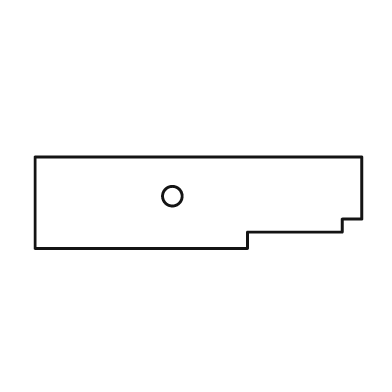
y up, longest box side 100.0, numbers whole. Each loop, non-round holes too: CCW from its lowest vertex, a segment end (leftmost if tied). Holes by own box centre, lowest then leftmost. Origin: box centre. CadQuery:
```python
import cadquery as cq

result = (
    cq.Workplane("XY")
    .moveTo(-50.0, -14.0)
    .lineTo(15.0, -14.0)
    .lineTo(15.0, -9.0)
    .lineTo(44.0, -9.0)
    .lineTo(44.0, -5.0)
    .lineTo(50.0, -5.0)
    .lineTo(50.0, 14.0)
    .lineTo(-50.0, 14.0)
    .close()
    .moveTo(-8.0, 2.0)
    .circle(3.0)
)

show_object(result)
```